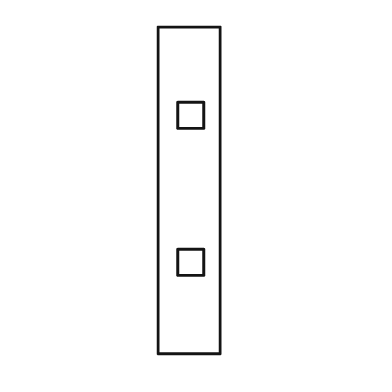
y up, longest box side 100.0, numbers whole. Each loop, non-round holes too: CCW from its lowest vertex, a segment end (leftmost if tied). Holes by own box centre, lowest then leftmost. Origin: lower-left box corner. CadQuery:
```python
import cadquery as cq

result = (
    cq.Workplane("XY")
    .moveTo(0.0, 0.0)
    .lineTo(19.0, 0.0)
    .lineTo(19.0, 100.0)
    .lineTo(0.0, 100.0)
    .close()
    .moveTo(6.0, 24.0)
    .lineTo(14.0, 24.0)
    .lineTo(14.0, 32.0)
    .lineTo(6.0, 32.0)
    .close()
    .moveTo(6.0, 69.0)
    .lineTo(14.0, 69.0)
    .lineTo(14.0, 77.0)
    .lineTo(6.0, 77.0)
    .close()
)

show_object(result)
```